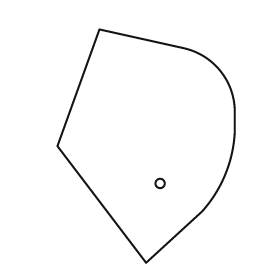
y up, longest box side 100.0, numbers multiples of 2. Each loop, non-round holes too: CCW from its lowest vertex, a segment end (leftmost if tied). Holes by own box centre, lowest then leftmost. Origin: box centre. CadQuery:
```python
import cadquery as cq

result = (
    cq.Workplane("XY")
    .moveTo(0.0, -50.0)
    .lineTo(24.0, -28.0)
    .threePointArc((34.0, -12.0), (38.0, 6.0))
    .lineTo(38.0, 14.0)
    .threePointArc((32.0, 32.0), (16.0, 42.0))
    .lineTo(-20.0, 50.0)
    .lineTo(-38.0, 0.0)
    .close()
    .moveTo(6.0, -16.0)
    .circle(2.0)
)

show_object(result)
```